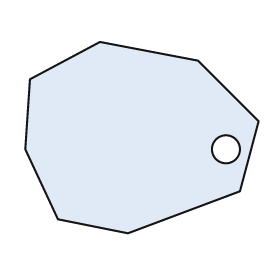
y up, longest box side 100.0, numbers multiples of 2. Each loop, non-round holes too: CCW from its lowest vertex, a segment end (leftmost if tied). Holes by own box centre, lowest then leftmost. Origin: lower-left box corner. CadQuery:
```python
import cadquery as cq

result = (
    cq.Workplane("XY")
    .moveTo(44.0, 0.0)
    .lineTo(92.0, 18.0)
    .lineTo(100.0, 48.0)
    .lineTo(74.0, 74.0)
    .lineTo(32.0, 82.0)
    .lineTo(2.0, 66.0)
    .lineTo(0.0, 36.0)
    .lineTo(14.0, 6.0)
    .close()
    .moveTo(86.0, 36.0)
    .circle(6.0)
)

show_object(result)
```